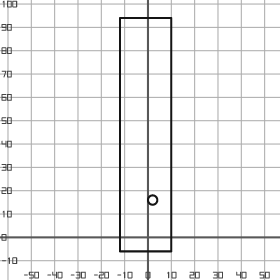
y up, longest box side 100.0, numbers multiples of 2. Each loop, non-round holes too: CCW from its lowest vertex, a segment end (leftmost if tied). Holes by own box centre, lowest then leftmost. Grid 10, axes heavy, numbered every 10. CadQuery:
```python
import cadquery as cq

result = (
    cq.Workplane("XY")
    .moveTo(-12.0, -6.0)
    .lineTo(10.0, -6.0)
    .lineTo(10.0, 94.0)
    .lineTo(-12.0, 94.0)
    .close()
    .moveTo(2.0, 16.0)
    .circle(2.0)
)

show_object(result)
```